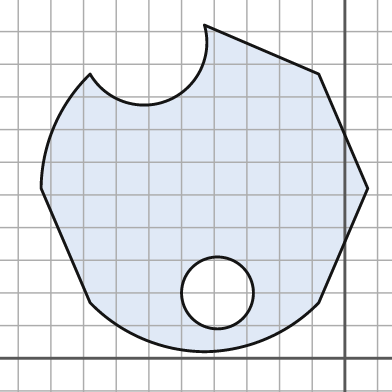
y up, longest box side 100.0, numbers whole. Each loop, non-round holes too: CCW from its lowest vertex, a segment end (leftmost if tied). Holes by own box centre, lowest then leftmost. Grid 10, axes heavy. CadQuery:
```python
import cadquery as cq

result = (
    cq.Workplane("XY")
    .moveTo(-43.0, 2.0)
    .threePointArc((-24.0, 6.0), (-8.0, 17.0))
    .lineTo(7.0, 52.0)
    .lineTo(-8.0, 87.0)
    .lineTo(-43.0, 102.0)
    .threePointArc((-54.0, 79.0), (-78.0, 87.0))
    .threePointArc((-89.0, 71.0), (-93.0, 52.0))
    .lineTo(-78.0, 17.0)
    .threePointArc((-62.0, 6.0), (-43.0, 2.0))
    .close()
    .moveTo(-39.0, 20.0)
    .circle(11.0)
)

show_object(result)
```